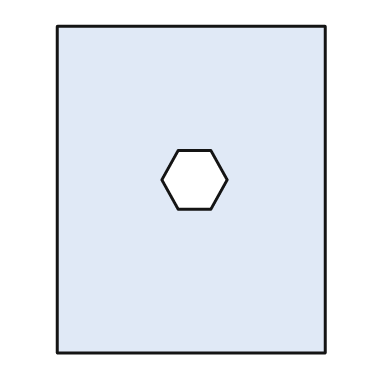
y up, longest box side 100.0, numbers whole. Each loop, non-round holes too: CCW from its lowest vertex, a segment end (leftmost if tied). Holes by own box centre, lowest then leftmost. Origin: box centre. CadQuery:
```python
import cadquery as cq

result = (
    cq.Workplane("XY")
    .moveTo(-41.0, -50.0)
    .lineTo(41.0, -50.0)
    .lineTo(41.0, 50.0)
    .lineTo(-41.0, 50.0)
    .close()
    .moveTo(-4.0, -6.0)
    .lineTo(6.0, -6.0)
    .lineTo(11.0, 3.0)
    .lineTo(6.0, 12.0)
    .lineTo(-4.0, 12.0)
    .lineTo(-9.0, 3.0)
    .close()
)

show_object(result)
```